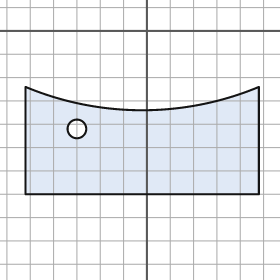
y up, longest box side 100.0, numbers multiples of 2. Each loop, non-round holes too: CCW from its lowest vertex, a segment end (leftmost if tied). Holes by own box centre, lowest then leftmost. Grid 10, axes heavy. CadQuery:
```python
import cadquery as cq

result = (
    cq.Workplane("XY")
    .moveTo(-52.0, -70.0)
    .lineTo(48.0, -70.0)
    .lineTo(48.0, -24.0)
    .threePointArc((-2.0, -34.0), (-52.0, -24.0))
    .close()
    .moveTo(-30.0, -42.0)
    .circle(4.0)
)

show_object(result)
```